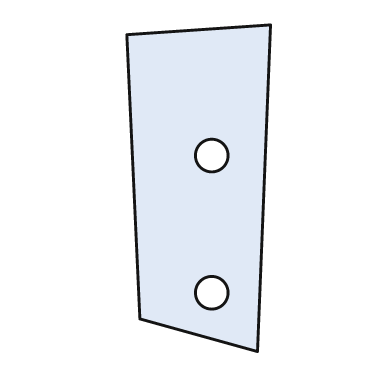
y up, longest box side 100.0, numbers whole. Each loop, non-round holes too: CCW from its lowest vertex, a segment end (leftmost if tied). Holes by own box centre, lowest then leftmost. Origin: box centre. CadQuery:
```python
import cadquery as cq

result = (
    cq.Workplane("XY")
    .moveTo(18.0, -50.0)
    .lineTo(22.0, 50.0)
    .lineTo(-22.0, 47.0)
    .lineTo(-18.0, -40.0)
    .close()
    .moveTo(4.0, -32.0)
    .circle(5.0)
    .moveTo(4.0, 10.0)
    .circle(5.0)
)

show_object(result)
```